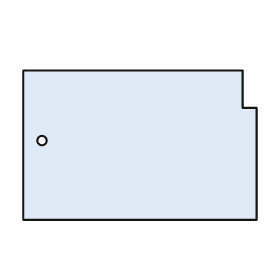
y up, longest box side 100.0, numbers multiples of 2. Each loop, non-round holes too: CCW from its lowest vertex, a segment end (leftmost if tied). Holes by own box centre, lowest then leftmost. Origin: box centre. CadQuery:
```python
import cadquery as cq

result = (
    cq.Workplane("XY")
    .moveTo(-50.0, -32.0)
    .lineTo(50.0, -32.0)
    .lineTo(50.0, 16.0)
    .lineTo(44.0, 16.0)
    .lineTo(44.0, 32.0)
    .lineTo(-50.0, 32.0)
    .close()
    .moveTo(-42.0, 2.0)
    .circle(2.0)
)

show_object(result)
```